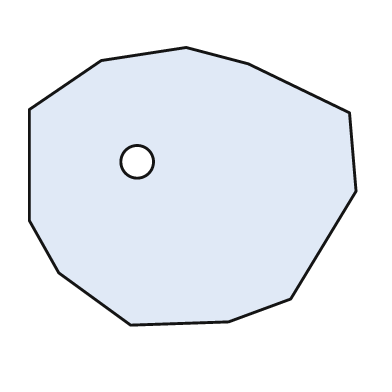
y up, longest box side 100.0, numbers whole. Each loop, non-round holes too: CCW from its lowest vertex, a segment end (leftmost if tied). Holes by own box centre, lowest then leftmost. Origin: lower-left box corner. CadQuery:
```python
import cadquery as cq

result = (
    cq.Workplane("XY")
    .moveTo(31.0, 0.0)
    .lineTo(61.0, 1.0)
    .lineTo(80.0, 8.0)
    .lineTo(100.0, 41.0)
    .lineTo(98.0, 65.0)
    .lineTo(67.0, 80.0)
    .lineTo(48.0, 85.0)
    .lineTo(22.0, 81.0)
    .lineTo(0.0, 66.0)
    .lineTo(0.0, 32.0)
    .lineTo(9.0, 16.0)
    .close()
    .moveTo(33.0, 50.0)
    .circle(5.0)
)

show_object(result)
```